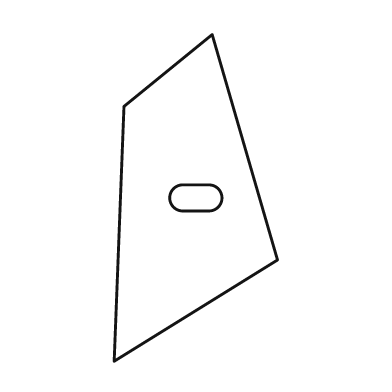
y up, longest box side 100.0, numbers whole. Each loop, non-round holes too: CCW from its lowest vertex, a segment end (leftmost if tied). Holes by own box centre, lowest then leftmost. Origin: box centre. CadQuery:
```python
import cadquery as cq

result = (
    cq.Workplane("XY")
    .moveTo(-25.0, -50.0)
    .lineTo(25.0, -19.0)
    .lineTo(5.0, 50.0)
    .lineTo(-22.0, 28.0)
    .close()
    .moveTo(-4.0, -4.0)
    .lineTo(4.0, -4.0)
    .threePointArc((8.0, 0.0), (4.0, 4.0))
    .lineTo(-4.0, 4.0)
    .threePointArc((-8.0, 0.0), (-4.0, -4.0))
    .close()
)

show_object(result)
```